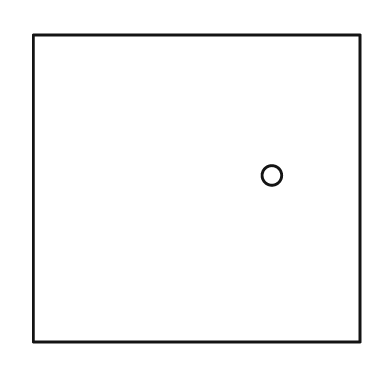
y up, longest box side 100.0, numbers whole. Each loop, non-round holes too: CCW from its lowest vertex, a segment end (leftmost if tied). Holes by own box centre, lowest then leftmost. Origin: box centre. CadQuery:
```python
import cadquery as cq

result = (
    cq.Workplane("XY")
    .moveTo(-50.0, -47.0)
    .lineTo(50.0, -47.0)
    .lineTo(50.0, 47.0)
    .lineTo(-50.0, 47.0)
    .close()
    .moveTo(23.0, 4.0)
    .circle(3.0)
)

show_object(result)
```